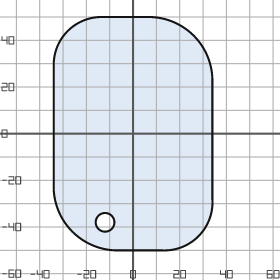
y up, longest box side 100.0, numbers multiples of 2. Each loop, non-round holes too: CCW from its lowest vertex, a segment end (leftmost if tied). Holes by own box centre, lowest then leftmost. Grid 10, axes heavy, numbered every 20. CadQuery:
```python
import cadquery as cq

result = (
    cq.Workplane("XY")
    .moveTo(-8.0, -50.0)
    .lineTo(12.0, -50.0)
    .threePointArc((28.0, -44.0), (34.0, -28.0))
    .lineTo(34.0, 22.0)
    .threePointArc((26.0, 42.0), (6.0, 50.0))
    .lineTo(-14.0, 50.0)
    .threePointArc((-28.0, 44.0), (-34.0, 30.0))
    .lineTo(-34.0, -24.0)
    .threePointArc((-26.0, -42.0), (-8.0, -50.0))
    .close()
    .moveTo(-12.0, -38.0)
    .circle(4.0)
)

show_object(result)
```